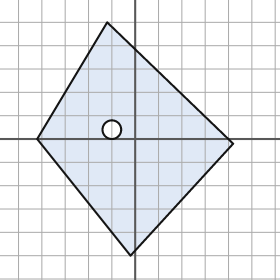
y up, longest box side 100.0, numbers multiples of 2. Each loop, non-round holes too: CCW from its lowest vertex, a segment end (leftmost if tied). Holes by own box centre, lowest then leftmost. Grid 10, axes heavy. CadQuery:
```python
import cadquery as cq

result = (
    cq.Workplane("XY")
    .moveTo(-2.0, -50.0)
    .lineTo(42.0, -2.0)
    .lineTo(-12.0, 50.0)
    .lineTo(-42.0, 0.0)
    .close()
    .moveTo(-10.0, 4.0)
    .circle(4.0)
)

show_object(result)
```